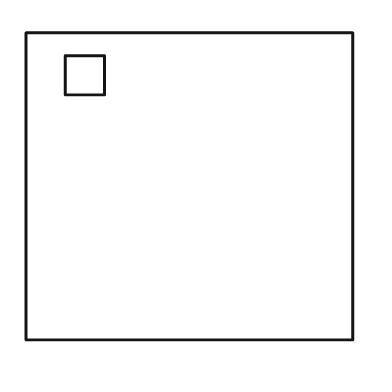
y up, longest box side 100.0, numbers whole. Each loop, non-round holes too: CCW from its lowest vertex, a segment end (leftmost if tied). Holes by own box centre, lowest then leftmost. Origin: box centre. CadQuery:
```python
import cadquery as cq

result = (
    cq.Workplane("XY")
    .moveTo(-50.0, -47.0)
    .lineTo(50.0, -47.0)
    .lineTo(50.0, 47.0)
    .lineTo(-50.0, 47.0)
    .close()
    .moveTo(-38.0, 28.0)
    .lineTo(-26.0, 28.0)
    .lineTo(-26.0, 40.0)
    .lineTo(-38.0, 40.0)
    .close()
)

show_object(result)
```